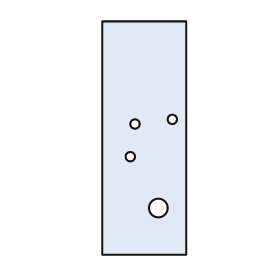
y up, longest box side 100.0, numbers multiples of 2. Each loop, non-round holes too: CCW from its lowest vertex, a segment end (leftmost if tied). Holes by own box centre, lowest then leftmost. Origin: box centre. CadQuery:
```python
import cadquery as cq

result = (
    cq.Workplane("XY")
    .moveTo(-18.0, -50.0)
    .lineTo(18.0, -50.0)
    .lineTo(18.0, 50.0)
    .lineTo(-18.0, 50.0)
    .close()
    .moveTo(6.0, -30.0)
    .circle(4.0)
    .moveTo(-6.0, -8.0)
    .circle(2.0)
    .moveTo(-4.0, 6.0)
    .circle(2.0)
    .moveTo(12.0, 8.0)
    .circle(2.0)
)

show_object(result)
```